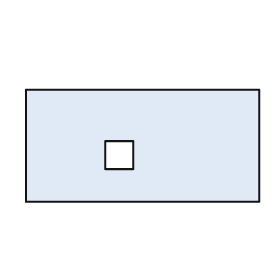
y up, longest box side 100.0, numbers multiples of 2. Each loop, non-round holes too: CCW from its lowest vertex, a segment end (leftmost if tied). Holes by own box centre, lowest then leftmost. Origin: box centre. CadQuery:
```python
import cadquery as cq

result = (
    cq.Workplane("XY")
    .moveTo(-50.0, -24.0)
    .lineTo(50.0, -24.0)
    .lineTo(50.0, 24.0)
    .lineTo(-50.0, 24.0)
    .close()
    .moveTo(-16.0, -10.0)
    .lineTo(-4.0, -10.0)
    .lineTo(-4.0, 2.0)
    .lineTo(-16.0, 2.0)
    .close()
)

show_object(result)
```